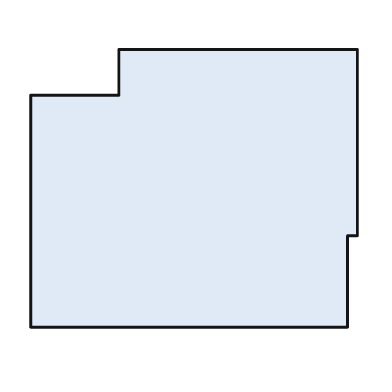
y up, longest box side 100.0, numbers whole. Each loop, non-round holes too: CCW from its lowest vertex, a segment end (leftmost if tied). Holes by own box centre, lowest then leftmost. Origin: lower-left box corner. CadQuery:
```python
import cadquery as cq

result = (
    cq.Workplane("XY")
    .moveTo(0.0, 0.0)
    .lineTo(97.0, 0.0)
    .lineTo(97.0, 28.0)
    .lineTo(100.0, 28.0)
    .lineTo(100.0, 85.0)
    .lineTo(27.0, 85.0)
    .lineTo(27.0, 71.0)
    .lineTo(0.0, 71.0)
    .close()
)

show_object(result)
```